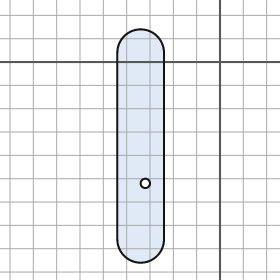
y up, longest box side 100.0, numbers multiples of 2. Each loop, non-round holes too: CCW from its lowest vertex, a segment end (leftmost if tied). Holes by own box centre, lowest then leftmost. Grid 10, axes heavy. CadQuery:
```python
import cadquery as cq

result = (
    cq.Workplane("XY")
    .moveTo(-44.0, -76.0)
    .threePointArc((-34.0, -86.0), (-24.0, -76.0))
    .lineTo(-24.0, 4.0)
    .threePointArc((-34.0, 14.0), (-44.0, 4.0))
    .close()
    .moveTo(-32.0, -52.0)
    .circle(2.0)
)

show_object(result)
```